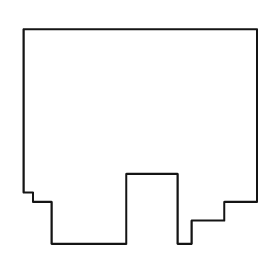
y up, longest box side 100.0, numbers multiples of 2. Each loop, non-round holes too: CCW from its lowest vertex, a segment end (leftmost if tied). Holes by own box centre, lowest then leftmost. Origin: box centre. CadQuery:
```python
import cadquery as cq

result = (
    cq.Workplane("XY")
    .moveTo(-38.0, -46.0)
    .lineTo(-6.0, -46.0)
    .lineTo(-6.0, -16.0)
    .lineTo(16.0, -16.0)
    .lineTo(16.0, -46.0)
    .lineTo(22.0, -46.0)
    .lineTo(22.0, -36.0)
    .lineTo(36.0, -36.0)
    .lineTo(36.0, -28.0)
    .lineTo(50.0, -28.0)
    .lineTo(50.0, 46.0)
    .lineTo(-50.0, 46.0)
    .lineTo(-50.0, -24.0)
    .lineTo(-46.0, -24.0)
    .lineTo(-46.0, -28.0)
    .lineTo(-38.0, -28.0)
    .close()
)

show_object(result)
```